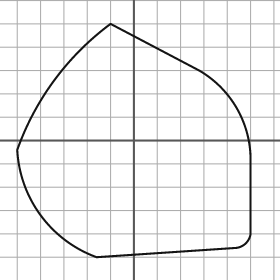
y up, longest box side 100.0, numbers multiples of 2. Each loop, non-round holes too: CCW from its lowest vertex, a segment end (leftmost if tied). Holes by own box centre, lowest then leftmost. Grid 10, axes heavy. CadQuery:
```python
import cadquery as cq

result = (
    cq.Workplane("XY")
    .moveTo(-16.0, -50.0)
    .lineTo(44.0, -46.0)
    .threePointArc((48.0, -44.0), (50.0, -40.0))
    .lineTo(50.0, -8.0)
    .threePointArc((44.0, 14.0), (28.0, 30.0))
    .lineTo(-10.0, 50.0)
    .threePointArc((-34.0, 26.0), (-50.0, -4.0))
    .threePointArc((-40.0, -32.0), (-16.0, -50.0))
    .close()
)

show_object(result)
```